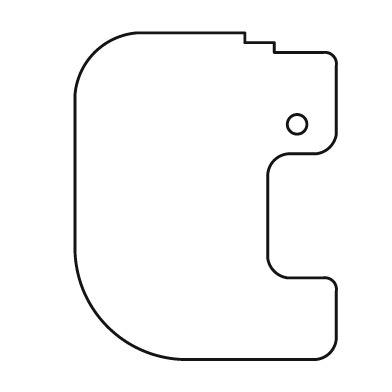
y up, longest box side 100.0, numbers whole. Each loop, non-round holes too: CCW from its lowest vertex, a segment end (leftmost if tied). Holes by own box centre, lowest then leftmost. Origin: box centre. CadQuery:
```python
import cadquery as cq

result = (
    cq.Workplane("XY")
    .moveTo(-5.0, -50.0)
    .lineTo(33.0, -50.0)
    .threePointArc((38.0, -48.0), (40.0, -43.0))
    .lineTo(40.0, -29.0)
    .threePointArc((39.0, -26.0), (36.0, -25.0))
    .lineTo(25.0, -25.0)
    .threePointArc((21.0, -23.0), (19.0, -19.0))
    .lineTo(19.0, 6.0)
    .threePointArc((21.0, 11.0), (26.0, 13.0))
    .lineTo(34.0, 13.0)
    .threePointArc((38.0, 15.0), (40.0, 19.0))
    .lineTo(40.0, 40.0)
    .threePointArc((39.0, 43.0), (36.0, 44.0))
    .lineTo(21.0, 44.0)
    .lineTo(21.0, 47.0)
    .lineTo(12.0, 47.0)
    .lineTo(12.0, 50.0)
    .lineTo(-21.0, 50.0)
    .threePointArc((-34.0, 44.0), (-40.0, 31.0))
    .lineTo(-40.0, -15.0)
    .threePointArc((-30.0, -40.0), (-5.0, -50.0))
    .close()
    .moveTo(28.0, 22.0)
    .circle(3.0)
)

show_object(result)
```